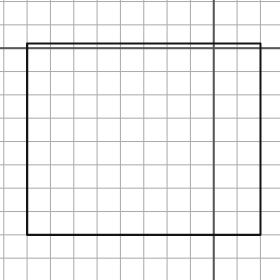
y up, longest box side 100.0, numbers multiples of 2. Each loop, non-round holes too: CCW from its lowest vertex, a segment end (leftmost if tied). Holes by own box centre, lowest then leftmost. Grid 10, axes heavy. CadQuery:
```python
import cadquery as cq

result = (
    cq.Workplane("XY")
    .moveTo(-80.0, -80.0)
    .lineTo(20.0, -80.0)
    .lineTo(20.0, 2.0)
    .lineTo(-80.0, 2.0)
    .close()
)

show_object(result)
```